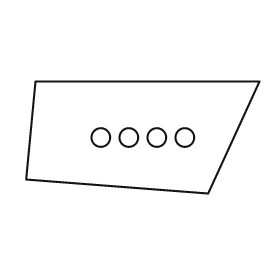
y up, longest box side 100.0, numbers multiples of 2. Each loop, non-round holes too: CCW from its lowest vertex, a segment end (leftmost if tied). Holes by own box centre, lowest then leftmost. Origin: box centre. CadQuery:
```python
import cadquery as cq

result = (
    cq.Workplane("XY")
    .moveTo(28.0, -24.0)
    .lineTo(50.0, 24.0)
    .lineTo(-46.0, 24.0)
    .lineTo(-50.0, -18.0)
    .close()
    .moveTo(-18.0, 0.0)
    .circle(4.0)
    .moveTo(-6.0, 0.0)
    .circle(4.0)
    .moveTo(6.0, 0.0)
    .circle(4.0)
    .moveTo(18.0, 0.0)
    .circle(4.0)
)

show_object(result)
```